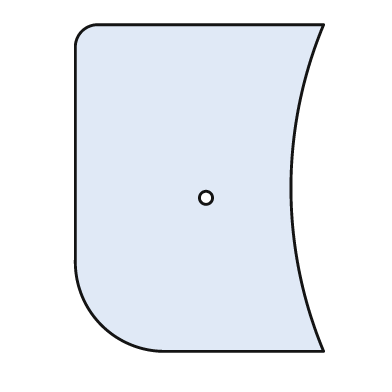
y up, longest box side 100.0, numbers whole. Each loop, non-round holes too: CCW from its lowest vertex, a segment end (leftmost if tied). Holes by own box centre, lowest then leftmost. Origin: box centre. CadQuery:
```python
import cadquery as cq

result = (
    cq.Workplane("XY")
    .moveTo(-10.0, -50.0)
    .lineTo(38.0, -50.0)
    .threePointArc((28.0, 0.0), (38.0, 50.0))
    .lineTo(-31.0, 50.0)
    .threePointArc((-36.0, 48.0), (-38.0, 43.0))
    .lineTo(-38.0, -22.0)
    .threePointArc((-30.0, -42.0), (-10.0, -50.0))
    .close()
    .moveTo(2.0, -3.0)
    .circle(2.0)
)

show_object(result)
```